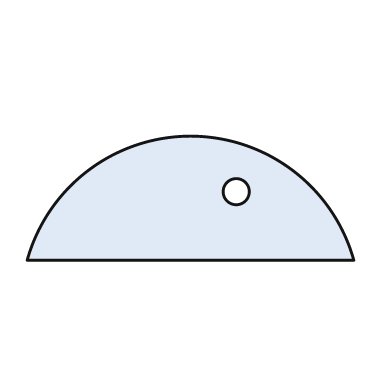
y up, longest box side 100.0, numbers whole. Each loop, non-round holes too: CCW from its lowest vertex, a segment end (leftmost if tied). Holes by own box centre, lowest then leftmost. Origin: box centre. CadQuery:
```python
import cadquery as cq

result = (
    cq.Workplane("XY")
    .moveTo(-50.0, -19.0)
    .lineTo(50.0, -19.0)
    .threePointArc((0.0, 19.0), (-50.0, -19.0))
    .close()
    .moveTo(14.0, 2.0)
    .circle(4.0)
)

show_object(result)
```